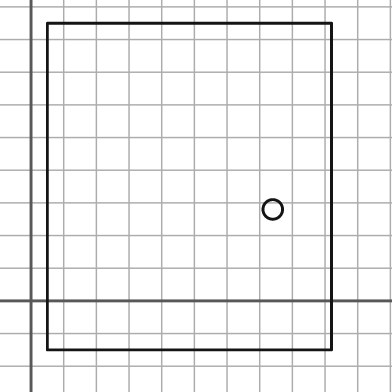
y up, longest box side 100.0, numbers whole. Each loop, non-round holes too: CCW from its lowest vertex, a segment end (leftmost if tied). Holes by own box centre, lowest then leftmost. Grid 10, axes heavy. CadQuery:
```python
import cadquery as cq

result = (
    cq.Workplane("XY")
    .moveTo(5.0, -15.0)
    .lineTo(92.0, -15.0)
    .lineTo(92.0, 85.0)
    .lineTo(5.0, 85.0)
    .close()
    .moveTo(74.0, 28.0)
    .circle(3.0)
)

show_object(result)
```